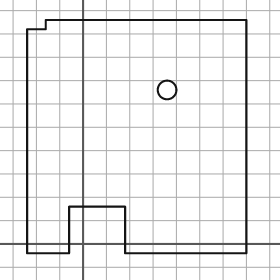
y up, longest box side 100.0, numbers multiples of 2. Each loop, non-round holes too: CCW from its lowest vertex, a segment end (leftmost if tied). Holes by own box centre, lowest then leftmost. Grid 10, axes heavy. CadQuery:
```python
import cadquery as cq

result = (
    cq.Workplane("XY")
    .moveTo(-24.0, -4.0)
    .lineTo(-6.0, -4.0)
    .lineTo(-6.0, 16.0)
    .lineTo(18.0, 16.0)
    .lineTo(18.0, -4.0)
    .lineTo(70.0, -4.0)
    .lineTo(70.0, 96.0)
    .lineTo(-16.0, 96.0)
    .lineTo(-16.0, 92.0)
    .lineTo(-24.0, 92.0)
    .close()
    .moveTo(36.0, 66.0)
    .circle(4.0)
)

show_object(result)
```